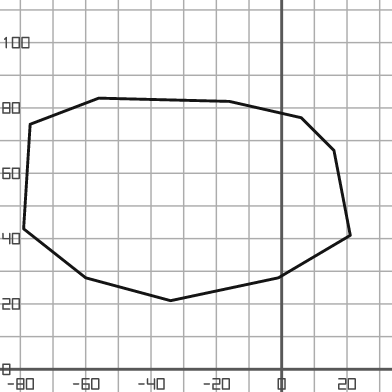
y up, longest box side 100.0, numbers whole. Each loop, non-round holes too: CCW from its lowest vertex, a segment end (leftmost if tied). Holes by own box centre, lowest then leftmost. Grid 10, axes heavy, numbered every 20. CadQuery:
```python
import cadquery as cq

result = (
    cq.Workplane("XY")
    .moveTo(-34.0, 21.0)
    .lineTo(-1.0, 28.0)
    .lineTo(21.0, 41.0)
    .lineTo(16.0, 67.0)
    .lineTo(6.0, 77.0)
    .lineTo(-16.0, 82.0)
    .lineTo(-56.0, 83.0)
    .lineTo(-77.0, 75.0)
    .lineTo(-79.0, 43.0)
    .lineTo(-60.0, 28.0)
    .close()
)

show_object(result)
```